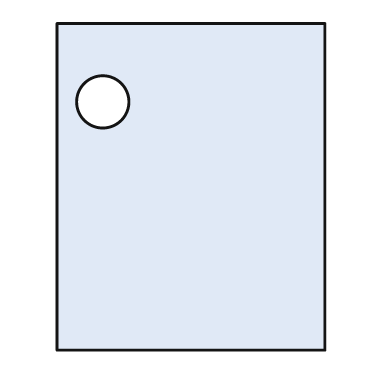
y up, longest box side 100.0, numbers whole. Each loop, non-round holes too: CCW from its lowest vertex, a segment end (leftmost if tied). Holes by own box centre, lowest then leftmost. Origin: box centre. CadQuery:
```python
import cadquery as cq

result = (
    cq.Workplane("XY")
    .moveTo(-41.0, -50.0)
    .lineTo(41.0, -50.0)
    .lineTo(41.0, 50.0)
    .lineTo(-41.0, 50.0)
    .close()
    .moveTo(-27.0, 26.0)
    .circle(8.0)
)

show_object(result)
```